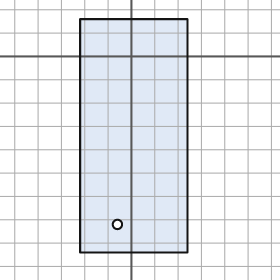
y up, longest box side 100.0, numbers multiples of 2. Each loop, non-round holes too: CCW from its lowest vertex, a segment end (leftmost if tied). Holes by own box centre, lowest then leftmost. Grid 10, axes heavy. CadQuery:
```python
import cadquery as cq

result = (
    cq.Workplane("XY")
    .moveTo(-22.0, -84.0)
    .lineTo(24.0, -84.0)
    .lineTo(24.0, 16.0)
    .lineTo(-22.0, 16.0)
    .close()
    .moveTo(-6.0, -72.0)
    .circle(2.0)
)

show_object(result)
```